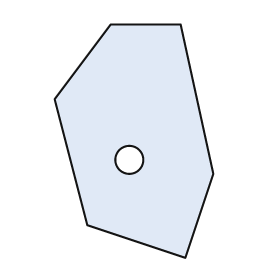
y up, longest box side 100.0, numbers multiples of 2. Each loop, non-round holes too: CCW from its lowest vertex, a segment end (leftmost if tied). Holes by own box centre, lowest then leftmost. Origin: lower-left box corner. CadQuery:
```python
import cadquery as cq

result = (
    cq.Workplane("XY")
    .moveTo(56.0, 0.0)
    .lineTo(68.0, 36.0)
    .lineTo(54.0, 100.0)
    .lineTo(24.0, 100.0)
    .lineTo(0.0, 68.0)
    .lineTo(14.0, 14.0)
    .close()
    .moveTo(32.0, 42.0)
    .circle(6.0)
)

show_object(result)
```